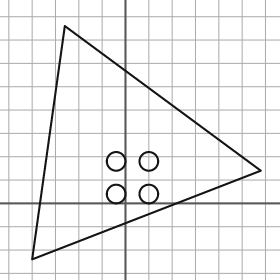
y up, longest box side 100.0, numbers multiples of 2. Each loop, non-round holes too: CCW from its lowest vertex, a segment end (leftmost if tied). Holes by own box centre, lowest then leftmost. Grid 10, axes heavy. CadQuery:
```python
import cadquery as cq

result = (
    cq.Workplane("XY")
    .moveTo(-40.0, -24.0)
    .lineTo(58.0, 14.0)
    .lineTo(-26.0, 76.0)
    .close()
    .moveTo(-4.0, 4.0)
    .circle(4.0)
    .moveTo(10.0, 4.0)
    .circle(4.0)
    .moveTo(-4.0, 18.0)
    .circle(4.0)
    .moveTo(10.0, 18.0)
    .circle(4.0)
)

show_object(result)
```